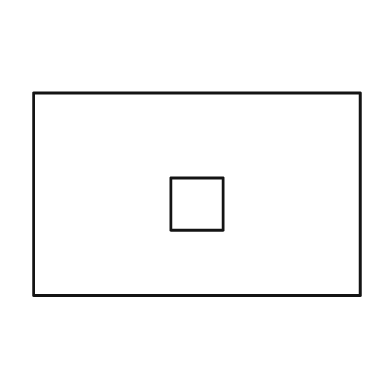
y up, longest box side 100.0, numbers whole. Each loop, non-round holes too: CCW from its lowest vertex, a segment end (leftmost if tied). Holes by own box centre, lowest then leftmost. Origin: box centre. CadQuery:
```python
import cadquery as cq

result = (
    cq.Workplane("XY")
    .moveTo(-50.0, -31.0)
    .lineTo(50.0, -31.0)
    .lineTo(50.0, 31.0)
    .lineTo(-50.0, 31.0)
    .close()
    .moveTo(-8.0, -11.0)
    .lineTo(8.0, -11.0)
    .lineTo(8.0, 5.0)
    .lineTo(-8.0, 5.0)
    .close()
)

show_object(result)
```